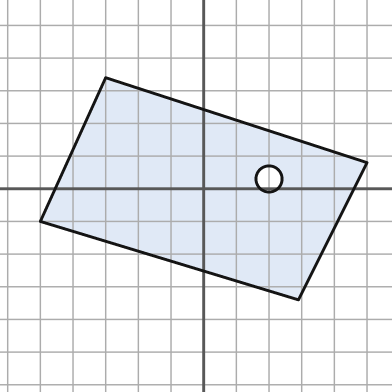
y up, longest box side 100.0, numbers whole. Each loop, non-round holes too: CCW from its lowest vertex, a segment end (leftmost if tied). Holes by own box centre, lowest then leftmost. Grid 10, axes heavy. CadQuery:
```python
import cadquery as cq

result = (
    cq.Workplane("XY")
    .moveTo(29.0, -34.0)
    .lineTo(50.0, 8.0)
    .lineTo(-30.0, 34.0)
    .lineTo(-50.0, -10.0)
    .close()
    .moveTo(20.0, 3.0)
    .circle(4.0)
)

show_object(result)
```